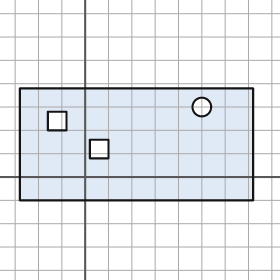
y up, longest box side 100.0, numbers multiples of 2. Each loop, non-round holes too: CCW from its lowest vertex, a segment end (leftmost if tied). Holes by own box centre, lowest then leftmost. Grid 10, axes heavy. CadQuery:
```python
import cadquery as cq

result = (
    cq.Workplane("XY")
    .moveTo(-28.0, -10.0)
    .lineTo(72.0, -10.0)
    .lineTo(72.0, 38.0)
    .lineTo(-28.0, 38.0)
    .close()
    .moveTo(2.0, 8.0)
    .lineTo(10.0, 8.0)
    .lineTo(10.0, 16.0)
    .lineTo(2.0, 16.0)
    .close()
    .moveTo(-16.0, 20.0)
    .lineTo(-8.0, 20.0)
    .lineTo(-8.0, 28.0)
    .lineTo(-16.0, 28.0)
    .close()
    .moveTo(50.0, 30.0)
    .circle(4.0)
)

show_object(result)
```